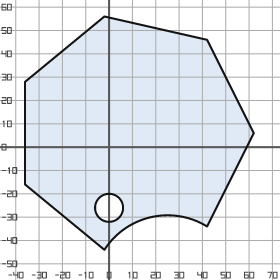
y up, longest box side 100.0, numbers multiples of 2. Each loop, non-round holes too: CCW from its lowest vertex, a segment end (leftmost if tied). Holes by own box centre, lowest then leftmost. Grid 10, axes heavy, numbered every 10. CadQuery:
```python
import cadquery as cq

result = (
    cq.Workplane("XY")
    .moveTo(-2.0, -44.0)
    .threePointArc((18.0, -30.0), (42.0, -34.0))
    .lineTo(62.0, 6.0)
    .lineTo(42.0, 46.0)
    .lineTo(-2.0, 56.0)
    .lineTo(-36.0, 28.0)
    .lineTo(-36.0, -16.0)
    .close()
    .moveTo(0.0, -26.0)
    .circle(6.0)
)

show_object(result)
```